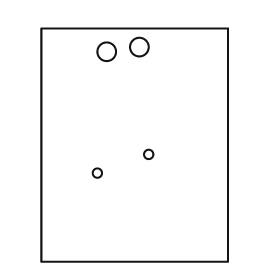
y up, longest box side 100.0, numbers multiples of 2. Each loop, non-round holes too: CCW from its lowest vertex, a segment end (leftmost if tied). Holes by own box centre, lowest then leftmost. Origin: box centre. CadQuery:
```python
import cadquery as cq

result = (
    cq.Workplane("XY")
    .moveTo(-40.0, -50.0)
    .lineTo(40.0, -50.0)
    .lineTo(40.0, 50.0)
    .lineTo(-40.0, 50.0)
    .close()
    .moveTo(-16.0, -12.0)
    .circle(2.0)
    .moveTo(6.0, -4.0)
    .circle(2.0)
    .moveTo(-12.0, 40.0)
    .circle(4.0)
    .moveTo(2.0, 42.0)
    .circle(4.0)
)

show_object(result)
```